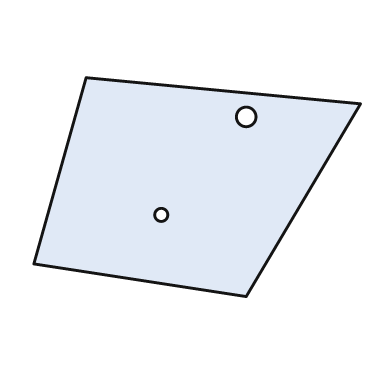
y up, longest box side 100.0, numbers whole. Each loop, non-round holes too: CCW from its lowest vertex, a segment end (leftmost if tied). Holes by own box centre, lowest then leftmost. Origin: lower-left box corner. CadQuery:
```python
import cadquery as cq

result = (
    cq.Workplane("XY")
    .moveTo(65.0, 0.0)
    .lineTo(100.0, 59.0)
    .lineTo(16.0, 67.0)
    .lineTo(0.0, 10.0)
    .close()
    .moveTo(39.0, 25.0)
    .circle(2.0)
    .moveTo(65.0, 55.0)
    .circle(3.0)
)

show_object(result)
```